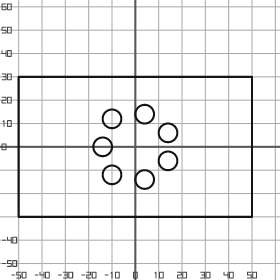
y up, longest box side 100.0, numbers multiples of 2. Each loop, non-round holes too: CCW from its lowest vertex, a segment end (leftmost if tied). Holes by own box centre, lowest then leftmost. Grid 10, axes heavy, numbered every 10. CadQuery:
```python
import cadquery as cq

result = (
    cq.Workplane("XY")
    .moveTo(-50.0, -30.0)
    .lineTo(50.0, -30.0)
    .lineTo(50.0, 30.0)
    .lineTo(-50.0, 30.0)
    .close()
    .moveTo(4.0, -14.0)
    .circle(4.0)
    .moveTo(-10.0, -12.0)
    .circle(4.0)
    .moveTo(14.0, -6.0)
    .circle(4.0)
    .moveTo(-14.0, 0.0)
    .circle(4.0)
    .moveTo(14.0, 6.0)
    .circle(4.0)
    .moveTo(-10.0, 12.0)
    .circle(4.0)
    .moveTo(4.0, 14.0)
    .circle(4.0)
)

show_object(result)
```